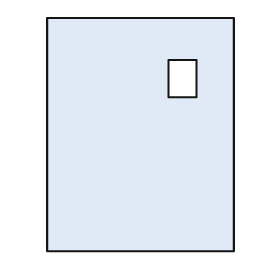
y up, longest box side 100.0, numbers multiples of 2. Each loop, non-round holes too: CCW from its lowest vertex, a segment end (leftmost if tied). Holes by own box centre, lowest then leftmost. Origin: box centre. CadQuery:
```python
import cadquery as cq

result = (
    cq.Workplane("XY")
    .moveTo(-40.0, -50.0)
    .lineTo(40.0, -50.0)
    .lineTo(40.0, 50.0)
    .lineTo(-40.0, 50.0)
    .close()
    .moveTo(12.0, 16.0)
    .lineTo(24.0, 16.0)
    .lineTo(24.0, 32.0)
    .lineTo(12.0, 32.0)
    .close()
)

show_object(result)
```